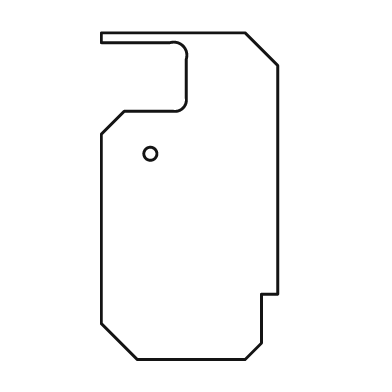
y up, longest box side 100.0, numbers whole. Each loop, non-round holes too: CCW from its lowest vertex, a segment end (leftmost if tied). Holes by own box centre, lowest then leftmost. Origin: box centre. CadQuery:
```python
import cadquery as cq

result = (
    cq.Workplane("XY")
    .moveTo(-16.0, -50.0)
    .lineTo(17.0, -50.0)
    .lineTo(22.0, -45.0)
    .lineTo(22.0, -30.0)
    .lineTo(27.0, -30.0)
    .lineTo(27.0, 40.0)
    .lineTo(17.0, 50.0)
    .lineTo(-27.0, 50.0)
    .lineTo(-27.0, 47.0)
    .lineTo(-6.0, 47.0)
    .threePointArc((-2.0, 46.0), (-1.0, 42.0))
    .lineTo(-1.0, 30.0)
    .threePointArc((-2.0, 27.0), (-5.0, 26.0))
    .lineTo(-20.0, 26.0)
    .lineTo(-27.0, 19.0)
    .lineTo(-27.0, -39.0)
    .close()
    .moveTo(-12.0, 13.0)
    .circle(2.0)
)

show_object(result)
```